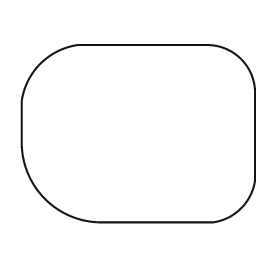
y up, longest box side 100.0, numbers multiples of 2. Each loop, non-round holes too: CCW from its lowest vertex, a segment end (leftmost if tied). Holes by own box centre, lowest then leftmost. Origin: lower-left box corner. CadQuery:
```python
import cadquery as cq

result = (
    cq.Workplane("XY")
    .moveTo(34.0, 0.0)
    .lineTo(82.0, 0.0)
    .threePointArc((94.0, 6.0), (100.0, 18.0))
    .lineTo(100.0, 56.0)
    .threePointArc((94.0, 70.0), (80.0, 76.0))
    .lineTo(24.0, 76.0)
    .threePointArc((8.0, 68.0), (0.0, 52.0))
    .lineTo(0.0, 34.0)
    .threePointArc((10.0, 10.0), (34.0, 0.0))
    .close()
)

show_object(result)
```